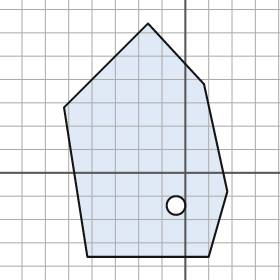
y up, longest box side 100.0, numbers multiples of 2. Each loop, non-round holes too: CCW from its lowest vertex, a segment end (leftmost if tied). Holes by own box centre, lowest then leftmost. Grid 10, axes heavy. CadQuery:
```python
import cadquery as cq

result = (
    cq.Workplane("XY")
    .moveTo(-42.0, -36.0)
    .lineTo(10.0, -36.0)
    .lineTo(18.0, -8.0)
    .lineTo(8.0, 38.0)
    .lineTo(-16.0, 64.0)
    .lineTo(-52.0, 28.0)
    .close()
    .moveTo(-4.0, -14.0)
    .circle(4.0)
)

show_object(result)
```